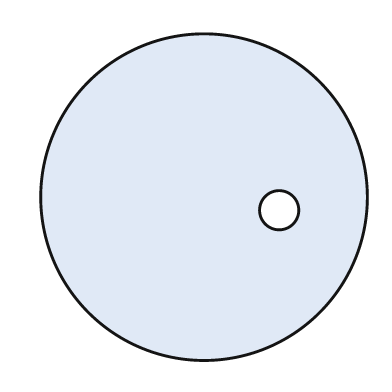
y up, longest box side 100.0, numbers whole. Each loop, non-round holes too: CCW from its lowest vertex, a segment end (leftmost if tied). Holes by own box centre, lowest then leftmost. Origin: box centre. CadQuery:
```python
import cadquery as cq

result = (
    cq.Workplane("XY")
    .moveTo(0.0, 0.0)
    .circle(50.0)
    .moveTo(23.0, -4.0)
    .circle(6.0)
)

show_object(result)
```